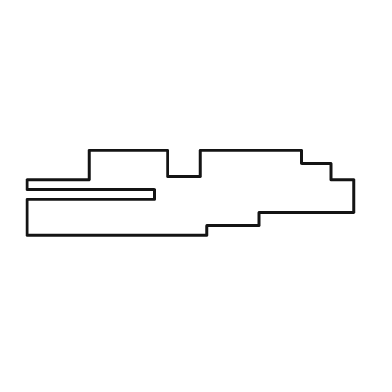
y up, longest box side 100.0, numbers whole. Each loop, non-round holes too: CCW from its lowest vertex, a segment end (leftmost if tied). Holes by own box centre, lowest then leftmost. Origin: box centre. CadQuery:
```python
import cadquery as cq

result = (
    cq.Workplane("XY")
    .moveTo(-50.0, -13.0)
    .lineTo(5.0, -13.0)
    .lineTo(5.0, -10.0)
    .lineTo(21.0, -10.0)
    .lineTo(21.0, -6.0)
    .lineTo(50.0, -6.0)
    .lineTo(50.0, 4.0)
    .lineTo(43.0, 4.0)
    .lineTo(43.0, 9.0)
    .lineTo(34.0, 9.0)
    .lineTo(34.0, 13.0)
    .lineTo(3.0, 13.0)
    .lineTo(3.0, 5.0)
    .lineTo(-7.0, 5.0)
    .lineTo(-7.0, 13.0)
    .lineTo(-31.0, 13.0)
    .lineTo(-31.0, 4.0)
    .lineTo(-50.0, 4.0)
    .lineTo(-50.0, 1.0)
    .lineTo(-11.0, 1.0)
    .lineTo(-11.0, -2.0)
    .lineTo(-50.0, -2.0)
    .close()
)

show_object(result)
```